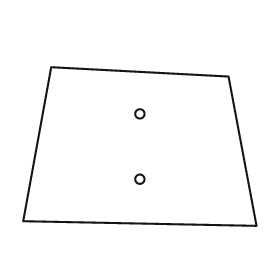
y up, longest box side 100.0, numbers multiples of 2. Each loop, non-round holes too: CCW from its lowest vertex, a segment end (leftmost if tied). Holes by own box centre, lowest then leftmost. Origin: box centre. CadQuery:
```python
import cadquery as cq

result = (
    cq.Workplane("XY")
    .moveTo(50.0, -34.0)
    .lineTo(38.0, 30.0)
    .lineTo(-38.0, 34.0)
    .lineTo(-50.0, -32.0)
    .close()
    .moveTo(0.0, -14.0)
    .circle(2.0)
    .moveTo(0.0, 14.0)
    .circle(2.0)
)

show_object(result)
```